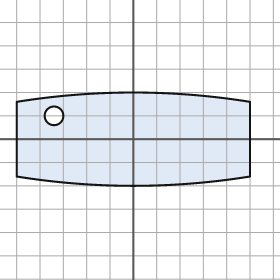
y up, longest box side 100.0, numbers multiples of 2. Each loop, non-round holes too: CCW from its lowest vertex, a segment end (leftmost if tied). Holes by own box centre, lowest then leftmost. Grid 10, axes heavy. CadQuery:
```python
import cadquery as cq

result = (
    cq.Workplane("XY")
    .moveTo(-50.0, -16.0)
    .threePointArc((0.0, -20.0), (50.0, -16.0))
    .lineTo(50.0, 16.0)
    .threePointArc((0.0, 20.0), (-50.0, 16.0))
    .close()
    .moveTo(-34.0, 10.0)
    .circle(4.0)
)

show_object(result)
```